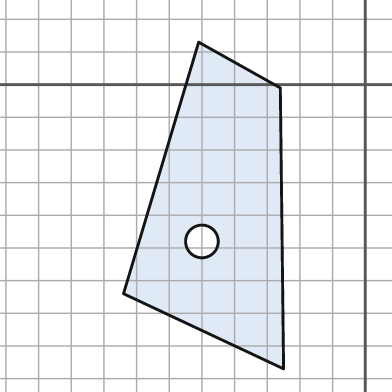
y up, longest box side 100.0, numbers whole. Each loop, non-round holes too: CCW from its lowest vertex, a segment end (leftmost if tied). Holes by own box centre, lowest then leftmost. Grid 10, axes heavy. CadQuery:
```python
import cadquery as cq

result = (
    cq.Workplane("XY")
    .moveTo(-25.0, -87.0)
    .lineTo(-26.0, -1.0)
    .lineTo(-51.0, 13.0)
    .lineTo(-74.0, -64.0)
    .close()
    .moveTo(-50.0, -48.0)
    .circle(5.0)
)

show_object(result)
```